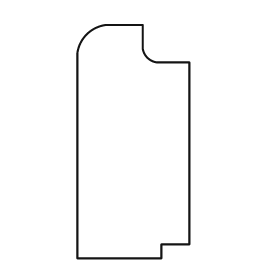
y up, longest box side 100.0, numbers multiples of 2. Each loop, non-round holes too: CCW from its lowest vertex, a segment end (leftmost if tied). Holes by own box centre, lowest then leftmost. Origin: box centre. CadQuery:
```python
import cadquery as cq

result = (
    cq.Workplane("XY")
    .moveTo(-24.0, -50.0)
    .lineTo(12.0, -50.0)
    .lineTo(12.0, -44.0)
    .lineTo(24.0, -44.0)
    .lineTo(24.0, 34.0)
    .lineTo(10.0, 34.0)
    .threePointArc((6.0, 36.0), (4.0, 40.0))
    .lineTo(4.0, 50.0)
    .lineTo(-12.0, 50.0)
    .threePointArc((-20.0, 46.0), (-24.0, 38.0))
    .close()
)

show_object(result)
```